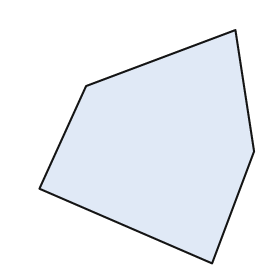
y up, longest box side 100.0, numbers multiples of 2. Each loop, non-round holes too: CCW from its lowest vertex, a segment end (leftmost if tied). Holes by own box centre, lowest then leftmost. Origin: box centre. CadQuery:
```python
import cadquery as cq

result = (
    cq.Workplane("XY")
    .moveTo(28.0, -50.0)
    .lineTo(46.0, -2.0)
    .lineTo(38.0, 50.0)
    .lineTo(-26.0, 26.0)
    .lineTo(-46.0, -18.0)
    .close()
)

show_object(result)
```